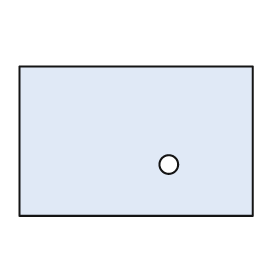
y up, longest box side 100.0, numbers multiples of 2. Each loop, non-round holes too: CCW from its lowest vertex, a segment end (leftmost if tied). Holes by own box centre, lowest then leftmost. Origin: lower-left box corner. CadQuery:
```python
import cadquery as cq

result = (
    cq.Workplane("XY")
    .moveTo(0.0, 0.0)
    .lineTo(100.0, 0.0)
    .lineTo(100.0, 64.0)
    .lineTo(0.0, 64.0)
    .close()
    .moveTo(64.0, 22.0)
    .circle(4.0)
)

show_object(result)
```